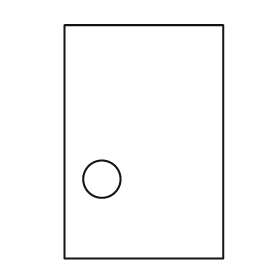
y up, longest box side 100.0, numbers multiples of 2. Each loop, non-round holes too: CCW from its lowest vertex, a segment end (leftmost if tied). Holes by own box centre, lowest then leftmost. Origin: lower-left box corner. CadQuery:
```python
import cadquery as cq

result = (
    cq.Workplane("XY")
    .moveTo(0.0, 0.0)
    .lineTo(68.0, 0.0)
    .lineTo(68.0, 100.0)
    .lineTo(0.0, 100.0)
    .close()
    .moveTo(16.0, 34.0)
    .circle(8.0)
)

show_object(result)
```